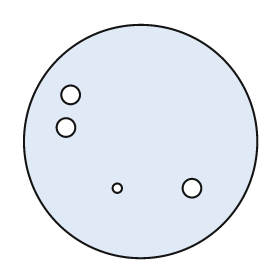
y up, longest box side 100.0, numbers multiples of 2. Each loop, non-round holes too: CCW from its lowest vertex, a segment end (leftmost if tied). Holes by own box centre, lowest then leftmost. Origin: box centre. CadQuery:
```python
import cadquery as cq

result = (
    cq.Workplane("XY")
    .moveTo(0.0, 0.0)
    .circle(50.0)
    .moveTo(-10.0, -20.0)
    .circle(2.0)
    .moveTo(22.0, -20.0)
    .circle(4.0)
    .moveTo(-32.0, 6.0)
    .circle(4.0)
    .moveTo(-30.0, 20.0)
    .circle(4.0)
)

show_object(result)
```